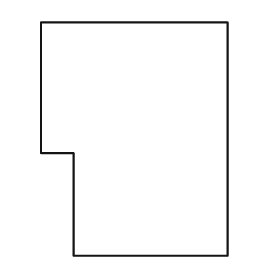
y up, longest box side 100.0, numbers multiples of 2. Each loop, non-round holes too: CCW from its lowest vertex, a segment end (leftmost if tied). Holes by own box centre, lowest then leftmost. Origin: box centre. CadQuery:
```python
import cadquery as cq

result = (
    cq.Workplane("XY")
    .moveTo(-26.0, -50.0)
    .lineTo(40.0, -50.0)
    .lineTo(40.0, 50.0)
    .lineTo(-40.0, 50.0)
    .lineTo(-40.0, -6.0)
    .lineTo(-26.0, -6.0)
    .close()
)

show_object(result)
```